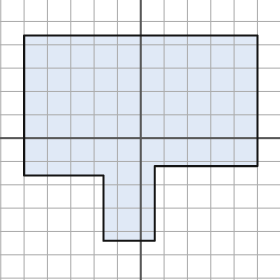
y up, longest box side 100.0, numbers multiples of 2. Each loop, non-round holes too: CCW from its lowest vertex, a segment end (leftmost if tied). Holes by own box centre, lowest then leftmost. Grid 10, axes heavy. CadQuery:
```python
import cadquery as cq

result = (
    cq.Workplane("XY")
    .moveTo(-16.0, -44.0)
    .lineTo(6.0, -44.0)
    .lineTo(6.0, -12.0)
    .lineTo(50.0, -12.0)
    .lineTo(50.0, 44.0)
    .lineTo(-50.0, 44.0)
    .lineTo(-50.0, -16.0)
    .lineTo(-16.0, -16.0)
    .close()
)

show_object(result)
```